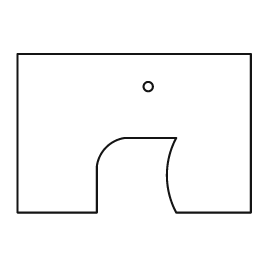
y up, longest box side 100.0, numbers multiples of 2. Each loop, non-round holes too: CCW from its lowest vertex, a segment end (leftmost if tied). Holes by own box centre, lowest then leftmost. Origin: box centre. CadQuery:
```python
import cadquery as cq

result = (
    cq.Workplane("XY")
    .moveTo(-50.0, -34.0)
    .lineTo(-16.0, -34.0)
    .lineTo(-16.0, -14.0)
    .threePointArc((-12.0, -6.0), (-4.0, -2.0))
    .lineTo(18.0, -2.0)
    .threePointArc((14.0, -18.0), (18.0, -34.0))
    .lineTo(50.0, -34.0)
    .lineTo(50.0, 34.0)
    .lineTo(-50.0, 34.0)
    .close()
    .moveTo(6.0, 20.0)
    .circle(2.0)
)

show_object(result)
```